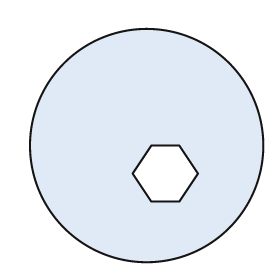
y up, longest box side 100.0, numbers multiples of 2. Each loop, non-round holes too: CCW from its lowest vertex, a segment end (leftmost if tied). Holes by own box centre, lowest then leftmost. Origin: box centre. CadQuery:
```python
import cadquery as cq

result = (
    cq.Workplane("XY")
    .moveTo(0.0, 0.0)
    .circle(50.0)
    .moveTo(2.0, -24.0)
    .lineTo(14.0, -24.0)
    .lineTo(22.0, -12.0)
    .lineTo(14.0, 0.0)
    .lineTo(2.0, 0.0)
    .lineTo(-6.0, -12.0)
    .close()
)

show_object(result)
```